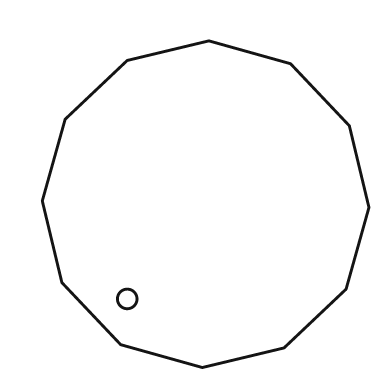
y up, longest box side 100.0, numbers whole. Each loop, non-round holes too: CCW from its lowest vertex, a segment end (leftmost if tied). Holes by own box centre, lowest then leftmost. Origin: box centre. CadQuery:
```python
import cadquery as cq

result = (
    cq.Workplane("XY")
    .moveTo(-1.0, -50.0)
    .lineTo(24.0, -44.0)
    .lineTo(43.0, -26.0)
    .lineTo(50.0, -1.0)
    .lineTo(44.0, 24.0)
    .lineTo(26.0, 43.0)
    .lineTo(1.0, 50.0)
    .lineTo(-24.0, 44.0)
    .lineTo(-43.0, 26.0)
    .lineTo(-50.0, 1.0)
    .lineTo(-44.0, -24.0)
    .lineTo(-26.0, -43.0)
    .close()
    .moveTo(-24.0, -29.0)
    .circle(3.0)
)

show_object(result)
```